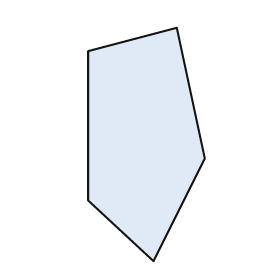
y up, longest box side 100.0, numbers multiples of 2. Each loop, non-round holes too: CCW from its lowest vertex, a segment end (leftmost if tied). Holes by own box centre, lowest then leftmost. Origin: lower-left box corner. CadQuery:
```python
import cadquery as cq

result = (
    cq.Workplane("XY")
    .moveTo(28.0, 0.0)
    .lineTo(50.0, 44.0)
    .lineTo(38.0, 100.0)
    .lineTo(0.0, 90.0)
    .lineTo(0.0, 26.0)
    .close()
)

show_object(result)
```